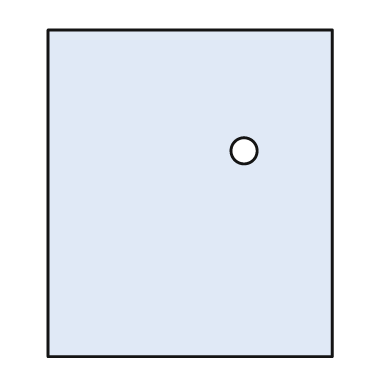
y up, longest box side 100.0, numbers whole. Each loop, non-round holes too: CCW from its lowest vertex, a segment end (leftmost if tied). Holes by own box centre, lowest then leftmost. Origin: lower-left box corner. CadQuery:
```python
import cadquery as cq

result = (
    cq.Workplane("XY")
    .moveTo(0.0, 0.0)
    .lineTo(87.0, 0.0)
    .lineTo(87.0, 100.0)
    .lineTo(0.0, 100.0)
    .close()
    .moveTo(60.0, 63.0)
    .circle(4.0)
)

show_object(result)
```